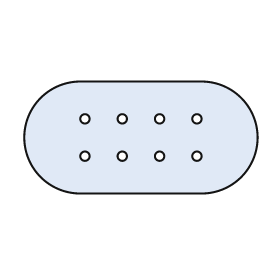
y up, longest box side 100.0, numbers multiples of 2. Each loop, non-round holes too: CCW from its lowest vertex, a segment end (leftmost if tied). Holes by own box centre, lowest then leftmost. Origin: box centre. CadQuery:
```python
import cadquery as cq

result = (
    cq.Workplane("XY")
    .moveTo(-26.0, -24.0)
    .lineTo(26.0, -24.0)
    .threePointArc((50.0, 0.0), (26.0, 24.0))
    .lineTo(-26.0, 24.0)
    .threePointArc((-50.0, 0.0), (-26.0, -24.0))
    .close()
    .moveTo(-24.0, -8.0)
    .circle(2.0)
    .moveTo(-8.0, -8.0)
    .circle(2.0)
    .moveTo(8.0, -8.0)
    .circle(2.0)
    .moveTo(24.0, -8.0)
    .circle(2.0)
    .moveTo(-24.0, 8.0)
    .circle(2.0)
    .moveTo(-8.0, 8.0)
    .circle(2.0)
    .moveTo(8.0, 8.0)
    .circle(2.0)
    .moveTo(24.0, 8.0)
    .circle(2.0)
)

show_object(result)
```